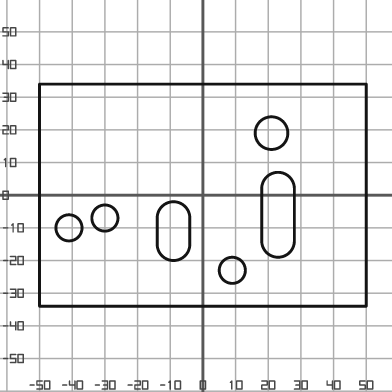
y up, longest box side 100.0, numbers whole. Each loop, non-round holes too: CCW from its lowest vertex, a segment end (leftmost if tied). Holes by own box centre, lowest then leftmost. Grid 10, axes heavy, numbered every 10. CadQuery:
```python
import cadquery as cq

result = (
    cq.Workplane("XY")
    .moveTo(-50.0, -34.0)
    .lineTo(50.0, -34.0)
    .lineTo(50.0, 34.0)
    .lineTo(-50.0, 34.0)
    .close()
    .moveTo(9.0, -23.0)
    .circle(4.0)
    .moveTo(-14.0, -15.0)
    .threePointArc((-9.0, -20.0), (-4.0, -15.0))
    .lineTo(-4.0, -7.0)
    .threePointArc((-9.0, -2.0), (-14.0, -7.0))
    .close()
    .moveTo(-41.0, -10.0)
    .circle(4.0)
    .moveTo(-30.0, -7.0)
    .circle(4.0)
    .moveTo(18.0, -14.0)
    .threePointArc((23.0, -19.0), (28.0, -14.0))
    .lineTo(28.0, 2.0)
    .threePointArc((23.0, 7.0), (18.0, 2.0))
    .close()
    .moveTo(21.0, 19.0)
    .circle(5.0)
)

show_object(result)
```